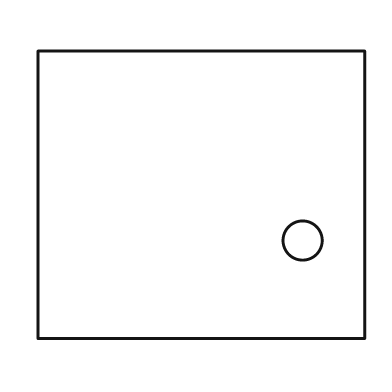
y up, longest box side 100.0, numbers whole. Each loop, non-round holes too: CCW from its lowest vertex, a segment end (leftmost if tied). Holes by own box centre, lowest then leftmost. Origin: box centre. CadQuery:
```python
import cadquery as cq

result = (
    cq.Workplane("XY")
    .moveTo(-50.0, -44.0)
    .lineTo(50.0, -44.0)
    .lineTo(50.0, 44.0)
    .lineTo(-50.0, 44.0)
    .close()
    .moveTo(31.0, -14.0)
    .circle(6.0)
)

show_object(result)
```